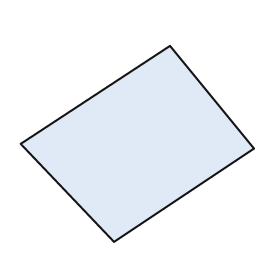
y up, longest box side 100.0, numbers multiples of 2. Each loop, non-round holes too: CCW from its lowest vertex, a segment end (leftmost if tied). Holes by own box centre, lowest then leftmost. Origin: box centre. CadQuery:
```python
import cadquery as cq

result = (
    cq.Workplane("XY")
    .moveTo(-10.0, -42.0)
    .lineTo(50.0, -2.0)
    .lineTo(14.0, 42.0)
    .lineTo(-50.0, 0.0)
    .close()
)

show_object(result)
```